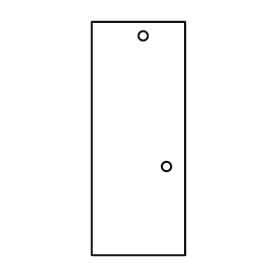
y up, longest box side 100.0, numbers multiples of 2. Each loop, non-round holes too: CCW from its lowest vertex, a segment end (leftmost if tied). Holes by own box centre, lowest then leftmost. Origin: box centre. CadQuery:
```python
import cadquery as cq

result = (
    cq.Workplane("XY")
    .moveTo(-20.0, -50.0)
    .lineTo(20.0, -50.0)
    .lineTo(20.0, 50.0)
    .lineTo(-20.0, 50.0)
    .close()
    .moveTo(12.0, -12.0)
    .circle(2.0)
    .moveTo(2.0, 44.0)
    .circle(2.0)
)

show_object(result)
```